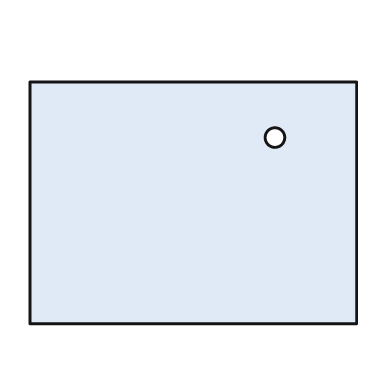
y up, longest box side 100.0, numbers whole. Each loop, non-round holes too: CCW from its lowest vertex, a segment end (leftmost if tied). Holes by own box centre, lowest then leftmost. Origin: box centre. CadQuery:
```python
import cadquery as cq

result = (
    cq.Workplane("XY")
    .moveTo(-50.0, -37.0)
    .lineTo(50.0, -37.0)
    .lineTo(50.0, 37.0)
    .lineTo(-50.0, 37.0)
    .close()
    .moveTo(25.0, 20.0)
    .circle(3.0)
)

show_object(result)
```